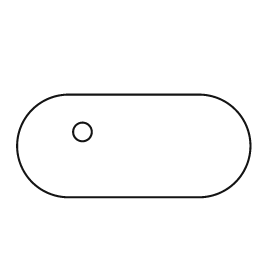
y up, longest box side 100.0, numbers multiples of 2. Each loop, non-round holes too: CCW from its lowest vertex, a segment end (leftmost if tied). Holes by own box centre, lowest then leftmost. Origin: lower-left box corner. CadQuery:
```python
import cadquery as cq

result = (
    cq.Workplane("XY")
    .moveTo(22.0, 0.0)
    .lineTo(78.0, 0.0)
    .threePointArc((100.0, 22.0), (78.0, 44.0))
    .lineTo(22.0, 44.0)
    .threePointArc((0.0, 22.0), (22.0, 0.0))
    .close()
    .moveTo(28.0, 28.0)
    .circle(4.0)
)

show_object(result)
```